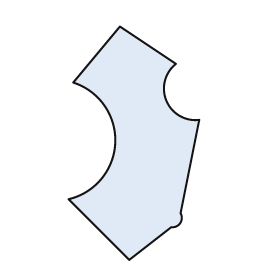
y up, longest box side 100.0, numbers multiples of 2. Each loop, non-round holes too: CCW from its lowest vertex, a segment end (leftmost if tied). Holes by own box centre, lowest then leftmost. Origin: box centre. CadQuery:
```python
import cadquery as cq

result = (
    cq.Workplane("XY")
    .moveTo(-2.0, -50.0)
    .lineTo(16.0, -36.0)
    .threePointArc((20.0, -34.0), (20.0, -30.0))
    .lineTo(28.0, 10.0)
    .threePointArc((14.0, 18.0), (18.0, 34.0))
    .lineTo(-6.0, 50.0)
    .lineTo(-26.0, 26.0)
    .threePointArc((-8.0, 0.0), (-28.0, -24.0))
    .close()
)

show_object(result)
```